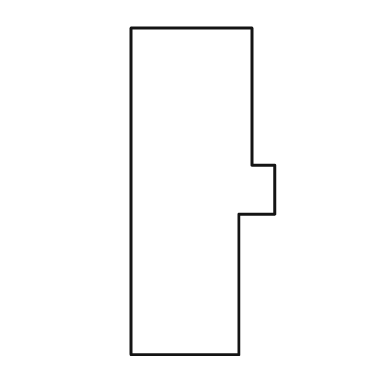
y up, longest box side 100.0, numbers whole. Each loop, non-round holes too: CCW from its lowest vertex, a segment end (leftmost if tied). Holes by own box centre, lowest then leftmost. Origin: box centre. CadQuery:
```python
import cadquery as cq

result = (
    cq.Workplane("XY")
    .moveTo(-22.0, -50.0)
    .lineTo(11.0, -50.0)
    .lineTo(11.0, -7.0)
    .lineTo(22.0, -7.0)
    .lineTo(22.0, 8.0)
    .lineTo(15.0, 8.0)
    .lineTo(15.0, 50.0)
    .lineTo(-22.0, 50.0)
    .close()
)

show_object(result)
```